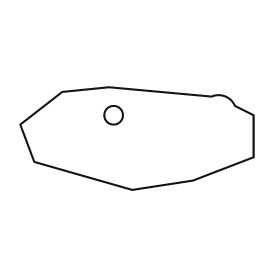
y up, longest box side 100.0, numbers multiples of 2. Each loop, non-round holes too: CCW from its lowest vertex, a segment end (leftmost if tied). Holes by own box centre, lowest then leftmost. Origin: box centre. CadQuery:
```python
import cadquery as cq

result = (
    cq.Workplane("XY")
    .moveTo(-2.0, -22.0)
    .lineTo(24.0, -18.0)
    .lineTo(50.0, -8.0)
    .lineTo(50.0, 10.0)
    .lineTo(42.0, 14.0)
    .threePointArc((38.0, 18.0), (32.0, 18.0))
    .lineTo(-12.0, 22.0)
    .lineTo(-32.0, 20.0)
    .lineTo(-50.0, 6.0)
    .lineTo(-44.0, -10.0)
    .close()
    .moveTo(-10.0, 10.0)
    .circle(4.0)
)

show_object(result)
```